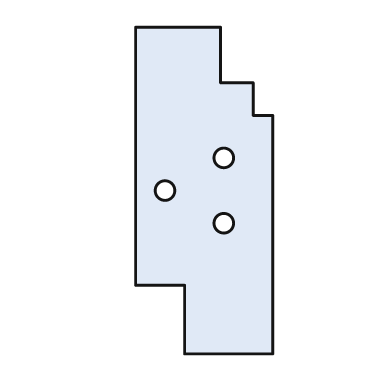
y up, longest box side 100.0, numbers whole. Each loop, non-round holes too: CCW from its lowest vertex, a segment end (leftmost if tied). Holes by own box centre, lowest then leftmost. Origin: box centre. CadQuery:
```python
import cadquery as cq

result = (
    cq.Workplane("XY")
    .moveTo(-6.0, -50.0)
    .lineTo(21.0, -50.0)
    .lineTo(21.0, 23.0)
    .lineTo(15.0, 23.0)
    .lineTo(15.0, 33.0)
    .lineTo(5.0, 33.0)
    .lineTo(5.0, 50.0)
    .lineTo(-21.0, 50.0)
    .lineTo(-21.0, -29.0)
    .lineTo(-6.0, -29.0)
    .close()
    .moveTo(6.0, -10.0)
    .circle(3.0)
    .moveTo(-12.0, 0.0)
    .circle(3.0)
    .moveTo(6.0, 10.0)
    .circle(3.0)
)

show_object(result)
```